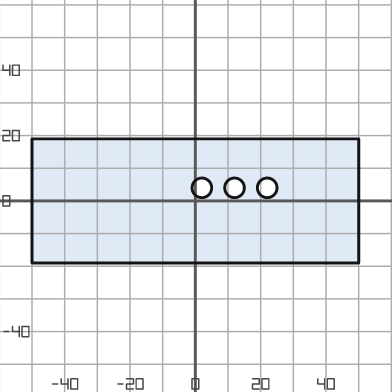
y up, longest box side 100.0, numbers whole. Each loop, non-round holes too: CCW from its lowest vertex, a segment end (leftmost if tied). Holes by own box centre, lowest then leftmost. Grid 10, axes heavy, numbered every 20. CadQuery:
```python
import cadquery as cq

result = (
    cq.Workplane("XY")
    .moveTo(-50.0, -19.0)
    .lineTo(50.0, -19.0)
    .lineTo(50.0, 19.0)
    .lineTo(-50.0, 19.0)
    .close()
    .moveTo(2.0, 4.0)
    .circle(3.0)
    .moveTo(12.0, 4.0)
    .circle(3.0)
    .moveTo(22.0, 4.0)
    .circle(3.0)
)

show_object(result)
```